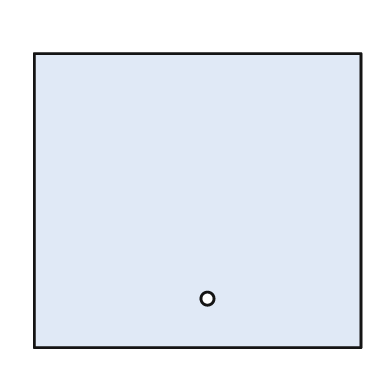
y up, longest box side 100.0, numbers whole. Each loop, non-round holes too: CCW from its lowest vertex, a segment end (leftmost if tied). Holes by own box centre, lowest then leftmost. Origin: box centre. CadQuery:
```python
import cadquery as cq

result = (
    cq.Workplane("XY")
    .moveTo(-50.0, -45.0)
    .lineTo(50.0, -45.0)
    .lineTo(50.0, 45.0)
    .lineTo(-50.0, 45.0)
    .close()
    .moveTo(3.0, -30.0)
    .circle(2.0)
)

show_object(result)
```